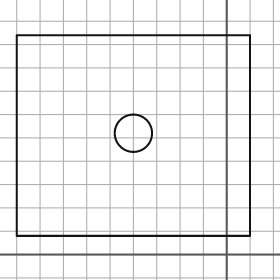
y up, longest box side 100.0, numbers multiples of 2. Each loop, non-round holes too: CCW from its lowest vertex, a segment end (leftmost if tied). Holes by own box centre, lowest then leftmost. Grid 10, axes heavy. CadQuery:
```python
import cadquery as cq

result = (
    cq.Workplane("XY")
    .moveTo(-90.0, 8.0)
    .lineTo(10.0, 8.0)
    .lineTo(10.0, 94.0)
    .lineTo(-90.0, 94.0)
    .close()
    .moveTo(-40.0, 52.0)
    .circle(8.0)
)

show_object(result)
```